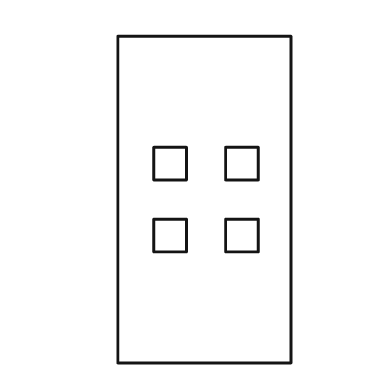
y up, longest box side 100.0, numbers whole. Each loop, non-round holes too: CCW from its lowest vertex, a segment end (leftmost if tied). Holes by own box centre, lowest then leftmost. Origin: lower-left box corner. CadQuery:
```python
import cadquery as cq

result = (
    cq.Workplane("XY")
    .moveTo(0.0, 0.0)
    .lineTo(53.0, 0.0)
    .lineTo(53.0, 100.0)
    .lineTo(0.0, 100.0)
    .close()
    .moveTo(11.0, 34.0)
    .lineTo(21.0, 34.0)
    .lineTo(21.0, 44.0)
    .lineTo(11.0, 44.0)
    .close()
    .moveTo(33.0, 34.0)
    .lineTo(43.0, 34.0)
    .lineTo(43.0, 44.0)
    .lineTo(33.0, 44.0)
    .close()
    .moveTo(11.0, 56.0)
    .lineTo(21.0, 56.0)
    .lineTo(21.0, 66.0)
    .lineTo(11.0, 66.0)
    .close()
    .moveTo(33.0, 56.0)
    .lineTo(43.0, 56.0)
    .lineTo(43.0, 66.0)
    .lineTo(33.0, 66.0)
    .close()
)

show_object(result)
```